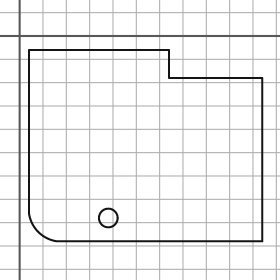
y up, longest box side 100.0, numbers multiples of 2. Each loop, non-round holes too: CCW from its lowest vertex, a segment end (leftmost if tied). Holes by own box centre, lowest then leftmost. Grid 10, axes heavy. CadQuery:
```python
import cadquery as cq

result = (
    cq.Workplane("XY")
    .moveTo(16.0, -88.0)
    .lineTo(104.0, -88.0)
    .lineTo(104.0, -18.0)
    .lineTo(64.0, -18.0)
    .lineTo(64.0, -6.0)
    .lineTo(4.0, -6.0)
    .lineTo(4.0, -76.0)
    .threePointArc((8.0, -84.0), (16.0, -88.0))
    .close()
    .moveTo(38.0, -78.0)
    .circle(4.0)
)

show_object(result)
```